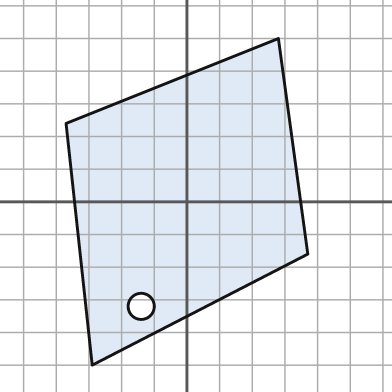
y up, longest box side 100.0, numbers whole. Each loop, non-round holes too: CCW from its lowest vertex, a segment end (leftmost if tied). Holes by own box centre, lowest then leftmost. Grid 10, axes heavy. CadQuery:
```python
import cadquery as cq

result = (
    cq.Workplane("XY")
    .moveTo(-29.0, -50.0)
    .lineTo(37.0, -16.0)
    .lineTo(28.0, 50.0)
    .lineTo(-37.0, 24.0)
    .close()
    .moveTo(-14.0, -32.0)
    .circle(4.0)
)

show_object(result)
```